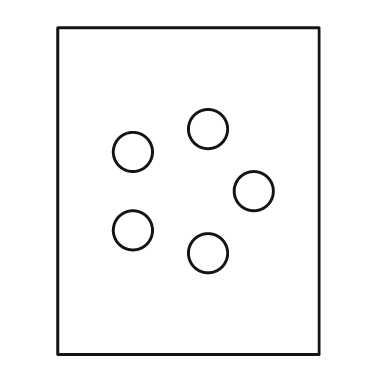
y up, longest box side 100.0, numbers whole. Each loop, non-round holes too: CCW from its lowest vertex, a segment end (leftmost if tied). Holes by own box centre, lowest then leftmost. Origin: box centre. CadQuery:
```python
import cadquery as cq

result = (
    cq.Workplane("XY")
    .moveTo(-40.0, -50.0)
    .lineTo(40.0, -50.0)
    .lineTo(40.0, 50.0)
    .lineTo(-40.0, 50.0)
    .close()
    .moveTo(6.0, -19.0)
    .circle(6.0)
    .moveTo(-17.0, -12.0)
    .circle(6.0)
    .moveTo(20.0, 0.0)
    .circle(6.0)
    .moveTo(-17.0, 12.0)
    .circle(6.0)
    .moveTo(6.0, 19.0)
    .circle(6.0)
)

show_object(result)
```